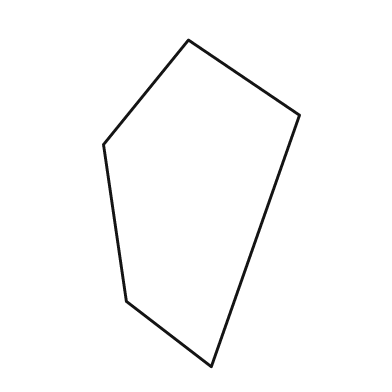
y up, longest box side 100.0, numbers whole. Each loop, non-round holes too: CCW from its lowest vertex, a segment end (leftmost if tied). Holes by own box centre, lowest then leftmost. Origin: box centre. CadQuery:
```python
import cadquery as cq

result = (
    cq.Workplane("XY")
    .moveTo(3.0, -50.0)
    .lineTo(30.0, 27.0)
    .lineTo(-4.0, 50.0)
    .lineTo(-30.0, 18.0)
    .lineTo(-23.0, -30.0)
    .close()
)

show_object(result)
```